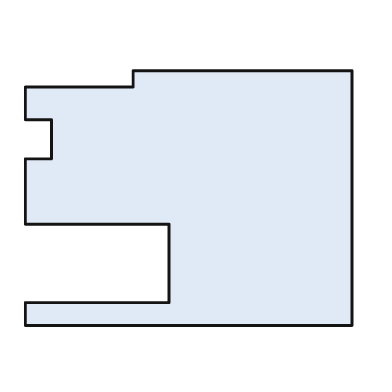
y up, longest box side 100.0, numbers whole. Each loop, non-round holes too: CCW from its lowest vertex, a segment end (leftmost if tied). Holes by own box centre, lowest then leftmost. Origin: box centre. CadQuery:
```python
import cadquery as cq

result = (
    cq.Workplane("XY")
    .moveTo(-50.0, -39.0)
    .lineTo(50.0, -39.0)
    .lineTo(50.0, 39.0)
    .lineTo(-17.0, 39.0)
    .lineTo(-17.0, 34.0)
    .lineTo(-50.0, 34.0)
    .lineTo(-50.0, 24.0)
    .lineTo(-42.0, 24.0)
    .lineTo(-42.0, 12.0)
    .lineTo(-50.0, 12.0)
    .lineTo(-50.0, -8.0)
    .lineTo(-6.0, -8.0)
    .lineTo(-6.0, -32.0)
    .lineTo(-50.0, -32.0)
    .close()
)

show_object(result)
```